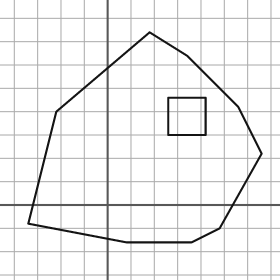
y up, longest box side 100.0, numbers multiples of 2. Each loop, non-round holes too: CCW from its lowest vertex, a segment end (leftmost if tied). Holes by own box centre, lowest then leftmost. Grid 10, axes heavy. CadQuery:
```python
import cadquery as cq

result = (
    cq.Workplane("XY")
    .moveTo(8.0, -16.0)
    .lineTo(36.0, -16.0)
    .lineTo(48.0, -10.0)
    .lineTo(66.0, 22.0)
    .lineTo(56.0, 42.0)
    .lineTo(34.0, 64.0)
    .lineTo(18.0, 74.0)
    .lineTo(-22.0, 40.0)
    .lineTo(-34.0, -8.0)
    .close()
    .moveTo(26.0, 30.0)
    .lineTo(42.0, 30.0)
    .lineTo(42.0, 46.0)
    .lineTo(26.0, 46.0)
    .close()
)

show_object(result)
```